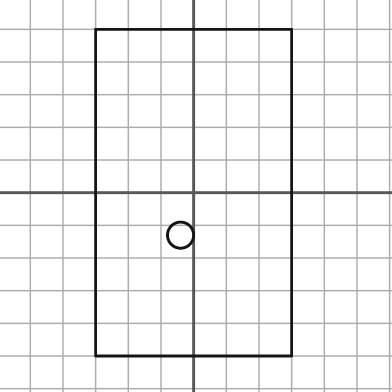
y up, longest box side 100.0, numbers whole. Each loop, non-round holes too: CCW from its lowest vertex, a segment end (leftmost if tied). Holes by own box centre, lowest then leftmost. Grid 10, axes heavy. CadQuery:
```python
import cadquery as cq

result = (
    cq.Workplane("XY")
    .moveTo(-30.0, -50.0)
    .lineTo(30.0, -50.0)
    .lineTo(30.0, 50.0)
    .lineTo(-30.0, 50.0)
    .close()
    .moveTo(-4.0, -13.0)
    .circle(4.0)
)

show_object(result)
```